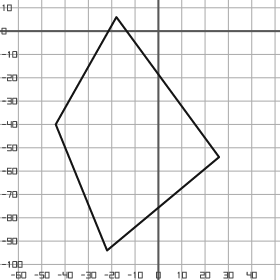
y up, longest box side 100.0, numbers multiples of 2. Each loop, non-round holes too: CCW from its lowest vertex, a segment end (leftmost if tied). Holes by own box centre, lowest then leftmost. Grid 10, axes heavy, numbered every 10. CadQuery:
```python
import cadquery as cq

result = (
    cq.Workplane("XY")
    .moveTo(-22.0, -94.0)
    .lineTo(26.0, -54.0)
    .lineTo(-18.0, 6.0)
    .lineTo(-44.0, -40.0)
    .close()
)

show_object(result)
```